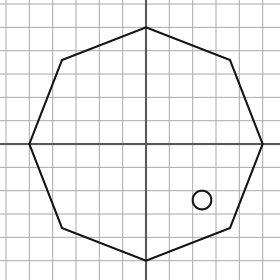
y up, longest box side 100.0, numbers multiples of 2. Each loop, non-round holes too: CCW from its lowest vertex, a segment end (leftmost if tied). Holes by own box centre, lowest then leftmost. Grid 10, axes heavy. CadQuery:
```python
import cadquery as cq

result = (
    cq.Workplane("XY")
    .moveTo(0.0, -50.0)
    .lineTo(36.0, -36.0)
    .lineTo(50.0, 0.0)
    .lineTo(36.0, 36.0)
    .lineTo(0.0, 50.0)
    .lineTo(-36.0, 36.0)
    .lineTo(-50.0, 0.0)
    .lineTo(-36.0, -36.0)
    .close()
    .moveTo(24.0, -24.0)
    .circle(4.0)
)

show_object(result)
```